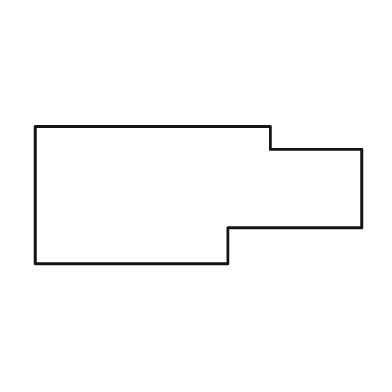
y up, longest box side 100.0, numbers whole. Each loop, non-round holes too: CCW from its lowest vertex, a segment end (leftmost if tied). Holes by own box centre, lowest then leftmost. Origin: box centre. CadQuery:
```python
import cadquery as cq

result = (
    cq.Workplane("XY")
    .moveTo(-50.0, -21.0)
    .lineTo(9.0, -21.0)
    .lineTo(9.0, -10.0)
    .lineTo(50.0, -10.0)
    .lineTo(50.0, 14.0)
    .lineTo(22.0, 14.0)
    .lineTo(22.0, 21.0)
    .lineTo(-50.0, 21.0)
    .close()
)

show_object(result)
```